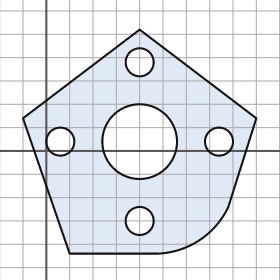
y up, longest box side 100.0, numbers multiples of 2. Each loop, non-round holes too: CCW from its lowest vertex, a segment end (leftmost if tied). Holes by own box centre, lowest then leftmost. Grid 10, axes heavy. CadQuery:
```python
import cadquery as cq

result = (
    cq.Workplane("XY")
    .moveTo(10.0, -44.0)
    .lineTo(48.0, -44.0)
    .threePointArc((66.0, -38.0), (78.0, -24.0))
    .lineTo(90.0, 14.0)
    .lineTo(40.0, 52.0)
    .lineTo(-10.0, 14.0)
    .close()
    .moveTo(40.0, -30.0)
    .circle(6.0)
    .moveTo(6.0, 4.0)
    .circle(6.0)
    .moveTo(40.0, 4.0)
    .circle(16.0)
    .moveTo(74.0, 4.0)
    .circle(6.0)
    .moveTo(40.0, 38.0)
    .circle(6.0)
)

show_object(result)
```